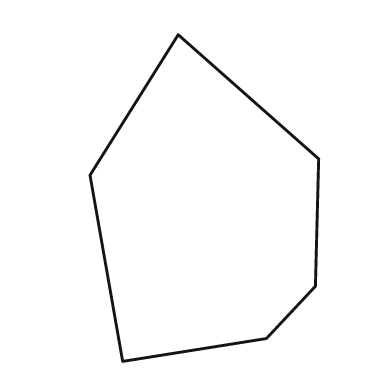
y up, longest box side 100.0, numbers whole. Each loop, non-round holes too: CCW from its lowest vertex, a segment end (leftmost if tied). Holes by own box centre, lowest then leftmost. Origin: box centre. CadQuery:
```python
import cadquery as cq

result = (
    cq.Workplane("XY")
    .moveTo(-25.0, -50.0)
    .lineTo(19.0, -43.0)
    .lineTo(34.0, -27.0)
    .lineTo(35.0, 12.0)
    .lineTo(-8.0, 50.0)
    .lineTo(-35.0, 7.0)
    .close()
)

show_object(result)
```